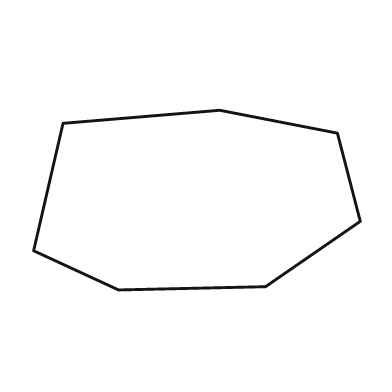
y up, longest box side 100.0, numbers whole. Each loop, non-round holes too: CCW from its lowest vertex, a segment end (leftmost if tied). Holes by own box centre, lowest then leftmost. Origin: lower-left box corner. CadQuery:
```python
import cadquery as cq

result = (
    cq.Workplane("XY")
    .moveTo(26.0, 0.0)
    .lineTo(71.0, 1.0)
    .lineTo(100.0, 21.0)
    .lineTo(93.0, 48.0)
    .lineTo(57.0, 55.0)
    .lineTo(9.0, 51.0)
    .lineTo(0.0, 12.0)
    .close()
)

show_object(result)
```